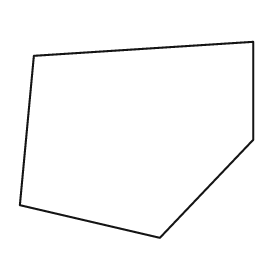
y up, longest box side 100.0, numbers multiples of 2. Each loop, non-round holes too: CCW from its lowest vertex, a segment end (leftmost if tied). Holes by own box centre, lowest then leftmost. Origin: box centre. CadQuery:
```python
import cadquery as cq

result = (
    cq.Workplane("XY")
    .moveTo(10.0, -42.0)
    .lineTo(50.0, 0.0)
    .lineTo(50.0, 42.0)
    .lineTo(-44.0, 36.0)
    .lineTo(-50.0, -28.0)
    .close()
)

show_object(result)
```